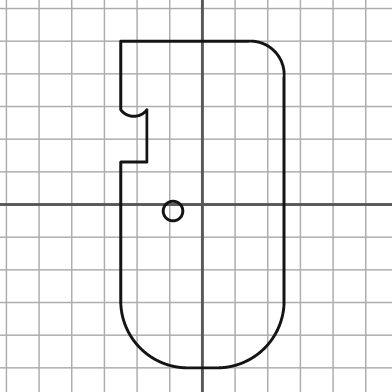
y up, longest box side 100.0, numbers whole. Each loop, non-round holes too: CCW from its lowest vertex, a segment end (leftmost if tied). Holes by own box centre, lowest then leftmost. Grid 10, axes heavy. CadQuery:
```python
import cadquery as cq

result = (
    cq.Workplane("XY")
    .moveTo(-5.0, -50.0)
    .lineTo(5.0, -50.0)
    .threePointArc((19.0, -44.0), (25.0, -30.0))
    .lineTo(25.0, 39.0)
    .threePointArc((22.0, 47.0), (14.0, 50.0))
    .lineTo(-25.0, 50.0)
    .lineTo(-25.0, 29.0)
    .threePointArc((-21.0, 27.0), (-17.0, 29.0))
    .lineTo(-17.0, 13.0)
    .lineTo(-25.0, 13.0)
    .lineTo(-25.0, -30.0)
    .threePointArc((-19.0, -44.0), (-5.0, -50.0))
    .close()
    .moveTo(-9.0, -2.0)
    .circle(3.0)
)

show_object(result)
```